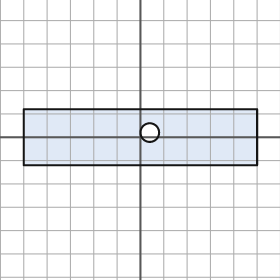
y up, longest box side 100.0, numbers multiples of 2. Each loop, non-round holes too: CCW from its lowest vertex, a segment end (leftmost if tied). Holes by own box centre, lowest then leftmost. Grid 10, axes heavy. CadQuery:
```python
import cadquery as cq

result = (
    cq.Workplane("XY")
    .moveTo(-50.0, -12.0)
    .lineTo(50.0, -12.0)
    .lineTo(50.0, 12.0)
    .lineTo(-50.0, 12.0)
    .close()
    .moveTo(4.0, 2.0)
    .circle(4.0)
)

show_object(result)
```